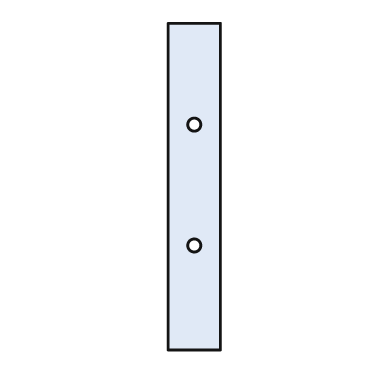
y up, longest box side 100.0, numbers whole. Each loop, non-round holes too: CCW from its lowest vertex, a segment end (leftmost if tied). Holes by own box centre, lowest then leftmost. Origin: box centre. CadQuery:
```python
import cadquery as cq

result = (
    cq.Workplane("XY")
    .moveTo(-8.0, -50.0)
    .lineTo(8.0, -50.0)
    .lineTo(8.0, 50.0)
    .lineTo(-8.0, 50.0)
    .close()
    .moveTo(0.0, -18.0)
    .circle(2.0)
    .moveTo(0.0, 19.0)
    .circle(2.0)
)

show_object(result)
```